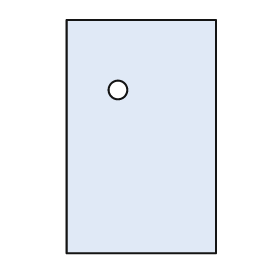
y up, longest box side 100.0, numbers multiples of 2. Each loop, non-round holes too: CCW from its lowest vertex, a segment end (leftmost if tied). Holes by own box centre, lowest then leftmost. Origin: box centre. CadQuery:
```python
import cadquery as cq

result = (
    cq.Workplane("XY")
    .moveTo(-32.0, -50.0)
    .lineTo(32.0, -50.0)
    .lineTo(32.0, 50.0)
    .lineTo(-32.0, 50.0)
    .close()
    .moveTo(-10.0, 20.0)
    .circle(4.0)
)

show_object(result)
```